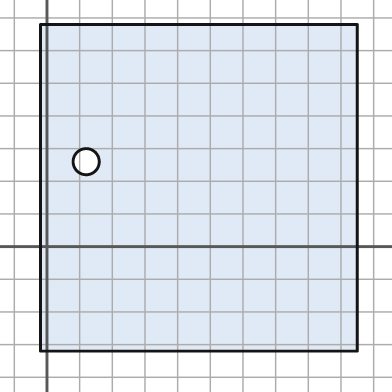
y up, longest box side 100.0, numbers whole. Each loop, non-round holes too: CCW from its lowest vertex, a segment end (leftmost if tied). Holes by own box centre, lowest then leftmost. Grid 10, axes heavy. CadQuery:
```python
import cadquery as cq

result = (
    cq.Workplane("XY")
    .moveTo(-2.0, -32.0)
    .lineTo(95.0, -32.0)
    .lineTo(95.0, 68.0)
    .lineTo(-2.0, 68.0)
    .close()
    .moveTo(12.0, 26.0)
    .circle(4.0)
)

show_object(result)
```